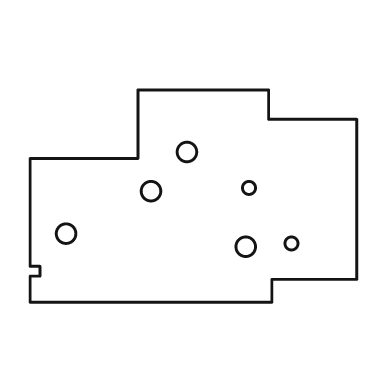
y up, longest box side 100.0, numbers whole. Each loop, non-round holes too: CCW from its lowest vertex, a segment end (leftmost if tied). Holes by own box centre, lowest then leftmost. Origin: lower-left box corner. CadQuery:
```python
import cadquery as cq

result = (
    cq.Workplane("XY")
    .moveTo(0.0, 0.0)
    .lineTo(74.0, 0.0)
    .lineTo(74.0, 7.0)
    .lineTo(100.0, 7.0)
    .lineTo(100.0, 56.0)
    .lineTo(73.0, 56.0)
    .lineTo(73.0, 65.0)
    .lineTo(33.0, 65.0)
    .lineTo(33.0, 44.0)
    .lineTo(0.0, 44.0)
    .lineTo(0.0, 11.0)
    .lineTo(3.0, 11.0)
    .lineTo(3.0, 8.0)
    .lineTo(0.0, 8.0)
    .close()
    .moveTo(66.0, 17.0)
    .circle(3.0)
    .moveTo(80.0, 18.0)
    .circle(2.0)
    .moveTo(11.0, 21.0)
    .circle(3.0)
    .moveTo(37.0, 34.0)
    .circle(3.0)
    .moveTo(67.0, 35.0)
    .circle(2.0)
    .moveTo(48.0, 46.0)
    .circle(3.0)
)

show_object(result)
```